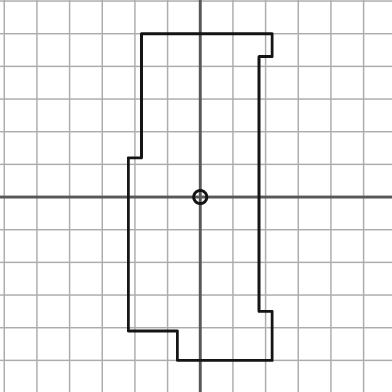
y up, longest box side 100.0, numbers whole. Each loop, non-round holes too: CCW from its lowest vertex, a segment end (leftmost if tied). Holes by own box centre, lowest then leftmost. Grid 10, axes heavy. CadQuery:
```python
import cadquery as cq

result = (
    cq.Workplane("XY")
    .moveTo(-7.0, -50.0)
    .lineTo(22.0, -50.0)
    .lineTo(22.0, -35.0)
    .lineTo(18.0, -35.0)
    .lineTo(18.0, 43.0)
    .lineTo(22.0, 43.0)
    .lineTo(22.0, 50.0)
    .lineTo(-18.0, 50.0)
    .lineTo(-18.0, 12.0)
    .lineTo(-22.0, 12.0)
    .lineTo(-22.0, -41.0)
    .lineTo(-7.0, -41.0)
    .close()
    .moveTo(0.0, 0.0)
    .circle(2.0)
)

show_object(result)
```